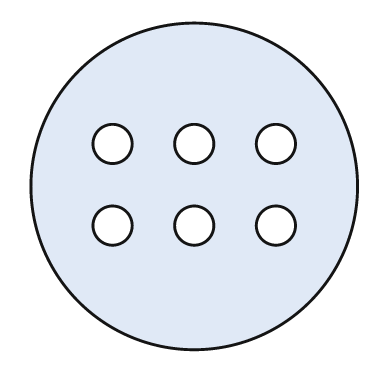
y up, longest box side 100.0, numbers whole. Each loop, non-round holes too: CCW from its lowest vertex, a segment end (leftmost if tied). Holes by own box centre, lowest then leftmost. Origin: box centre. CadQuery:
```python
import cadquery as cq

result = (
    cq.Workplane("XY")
    .moveTo(0.0, 0.0)
    .circle(50.0)
    .moveTo(-25.0, -12.0)
    .circle(6.0)
    .moveTo(0.0, -12.0)
    .circle(6.0)
    .moveTo(25.0, -12.0)
    .circle(6.0)
    .moveTo(-25.0, 13.0)
    .circle(6.0)
    .moveTo(0.0, 13.0)
    .circle(6.0)
    .moveTo(25.0, 13.0)
    .circle(6.0)
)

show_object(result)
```